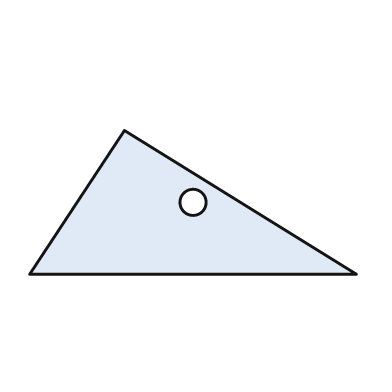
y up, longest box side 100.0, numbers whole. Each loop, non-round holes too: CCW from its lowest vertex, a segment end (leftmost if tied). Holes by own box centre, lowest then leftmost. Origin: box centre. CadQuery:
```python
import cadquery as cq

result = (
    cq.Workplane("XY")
    .moveTo(-50.0, -22.0)
    .lineTo(50.0, -22.0)
    .lineTo(-21.0, 22.0)
    .close()
    .moveTo(0.0, 0.0)
    .circle(4.0)
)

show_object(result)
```